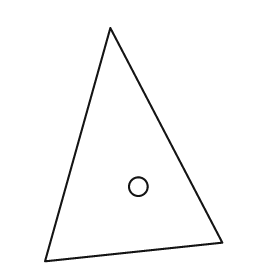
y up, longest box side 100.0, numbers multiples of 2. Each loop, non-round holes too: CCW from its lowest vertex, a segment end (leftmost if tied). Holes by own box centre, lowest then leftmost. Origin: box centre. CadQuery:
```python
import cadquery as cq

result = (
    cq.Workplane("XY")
    .moveTo(-38.0, -50.0)
    .lineTo(38.0, -42.0)
    .lineTo(-10.0, 50.0)
    .close()
    .moveTo(2.0, -18.0)
    .circle(4.0)
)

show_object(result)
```